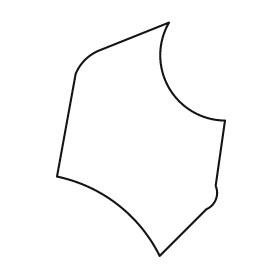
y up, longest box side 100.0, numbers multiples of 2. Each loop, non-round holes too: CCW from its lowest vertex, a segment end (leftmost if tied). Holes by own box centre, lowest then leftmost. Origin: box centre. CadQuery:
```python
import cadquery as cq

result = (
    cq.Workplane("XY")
    .moveTo(8.0, -50.0)
    .lineTo(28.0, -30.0)
    .threePointArc((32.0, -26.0), (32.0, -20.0))
    .lineTo(36.0, 8.0)
    .threePointArc((12.0, 22.0), (12.0, 50.0))
    .lineTo(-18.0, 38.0)
    .threePointArc((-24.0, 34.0), (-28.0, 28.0))
    .lineTo(-36.0, -16.0)
    .threePointArc((-10.0, -28.0), (8.0, -50.0))
    .close()
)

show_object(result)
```